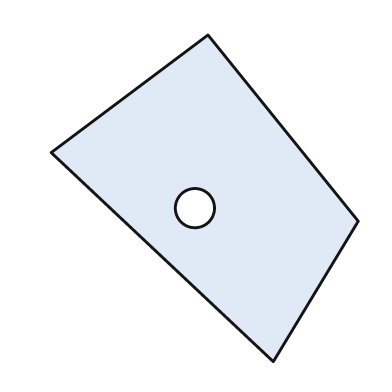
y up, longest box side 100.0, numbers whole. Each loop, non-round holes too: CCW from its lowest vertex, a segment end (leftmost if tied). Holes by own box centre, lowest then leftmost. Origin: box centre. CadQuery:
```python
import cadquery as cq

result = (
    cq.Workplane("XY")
    .moveTo(21.0, -50.0)
    .lineTo(47.0, -7.0)
    .lineTo(1.0, 50.0)
    .lineTo(-47.0, 14.0)
    .close()
    .moveTo(-3.0, -3.0)
    .circle(6.0)
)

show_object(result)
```